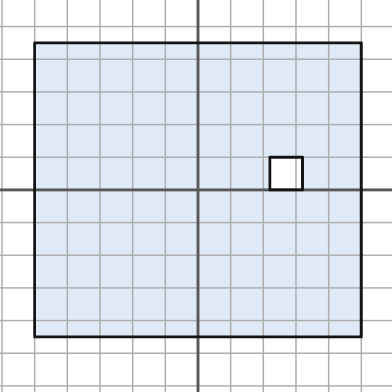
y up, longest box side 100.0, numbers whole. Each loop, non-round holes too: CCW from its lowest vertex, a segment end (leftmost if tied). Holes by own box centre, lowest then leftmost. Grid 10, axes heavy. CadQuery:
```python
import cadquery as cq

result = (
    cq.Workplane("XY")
    .moveTo(-50.0, -45.0)
    .lineTo(50.0, -45.0)
    .lineTo(50.0, 45.0)
    .lineTo(-50.0, 45.0)
    .close()
    .moveTo(22.0, 0.0)
    .lineTo(32.0, 0.0)
    .lineTo(32.0, 10.0)
    .lineTo(22.0, 10.0)
    .close()
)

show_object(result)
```